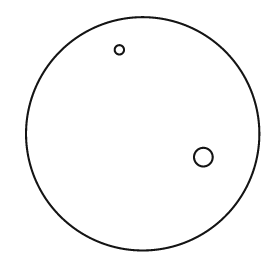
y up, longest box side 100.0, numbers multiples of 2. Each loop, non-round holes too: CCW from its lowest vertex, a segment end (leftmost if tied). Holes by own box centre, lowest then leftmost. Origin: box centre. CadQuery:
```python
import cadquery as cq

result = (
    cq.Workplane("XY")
    .moveTo(0.0, 0.0)
    .circle(50.0)
    .moveTo(26.0, -10.0)
    .circle(4.0)
    .moveTo(-10.0, 36.0)
    .circle(2.0)
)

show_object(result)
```